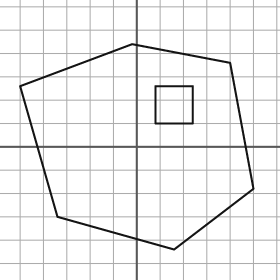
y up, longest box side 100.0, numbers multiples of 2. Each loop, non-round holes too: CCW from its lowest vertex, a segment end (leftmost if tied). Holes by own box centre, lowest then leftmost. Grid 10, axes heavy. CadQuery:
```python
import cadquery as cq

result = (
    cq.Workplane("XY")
    .moveTo(16.0, -44.0)
    .lineTo(50.0, -18.0)
    .lineTo(40.0, 36.0)
    .lineTo(-2.0, 44.0)
    .lineTo(-50.0, 26.0)
    .lineTo(-34.0, -30.0)
    .close()
    .moveTo(8.0, 10.0)
    .lineTo(24.0, 10.0)
    .lineTo(24.0, 26.0)
    .lineTo(8.0, 26.0)
    .close()
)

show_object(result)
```